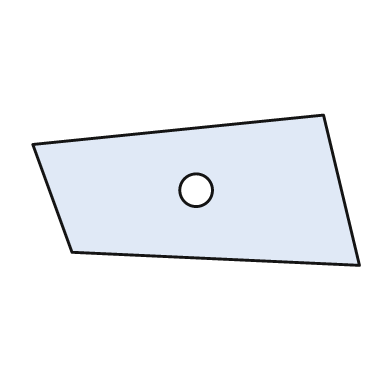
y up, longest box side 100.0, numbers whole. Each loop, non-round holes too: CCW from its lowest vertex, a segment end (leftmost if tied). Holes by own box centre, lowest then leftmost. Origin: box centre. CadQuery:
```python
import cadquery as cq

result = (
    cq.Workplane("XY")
    .moveTo(50.0, -23.0)
    .lineTo(39.0, 23.0)
    .lineTo(-50.0, 14.0)
    .lineTo(-38.0, -19.0)
    .close()
    .moveTo(0.0, 0.0)
    .circle(5.0)
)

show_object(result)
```